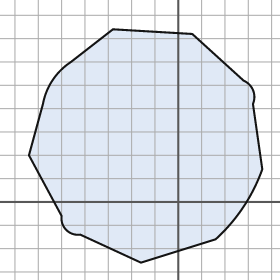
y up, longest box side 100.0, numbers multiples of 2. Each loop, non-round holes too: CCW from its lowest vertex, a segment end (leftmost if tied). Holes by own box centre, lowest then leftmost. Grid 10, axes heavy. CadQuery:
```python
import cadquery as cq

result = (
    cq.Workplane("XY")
    .moveTo(-16.0, -26.0)
    .lineTo(16.0, -16.0)
    .threePointArc((28.0, -2.0), (36.0, 14.0))
    .lineTo(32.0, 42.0)
    .threePointArc((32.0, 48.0), (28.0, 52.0))
    .lineTo(6.0, 72.0)
    .lineTo(-28.0, 74.0)
    .lineTo(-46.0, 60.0)
    .threePointArc((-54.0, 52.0), (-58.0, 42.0))
    .lineTo(-64.0, 20.0)
    .lineTo(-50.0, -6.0)
    .threePointArc((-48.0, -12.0), (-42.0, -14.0))
    .close()
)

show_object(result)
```